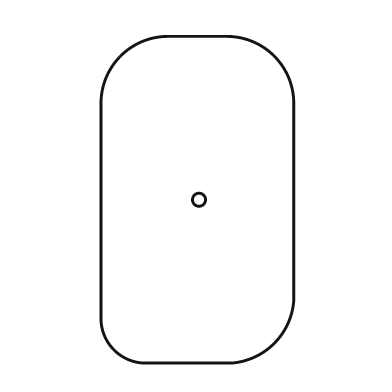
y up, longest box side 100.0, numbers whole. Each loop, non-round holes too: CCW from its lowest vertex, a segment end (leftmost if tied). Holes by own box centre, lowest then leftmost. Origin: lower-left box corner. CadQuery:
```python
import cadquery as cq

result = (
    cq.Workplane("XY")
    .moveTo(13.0, 0.0)
    .lineTo(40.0, 0.0)
    .threePointArc((53.0, 6.0), (59.0, 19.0))
    .lineTo(59.0, 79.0)
    .threePointArc((53.0, 94.0), (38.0, 100.0))
    .lineTo(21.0, 100.0)
    .threePointArc((6.0, 94.0), (0.0, 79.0))
    .lineTo(0.0, 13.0)
    .threePointArc((4.0, 4.0), (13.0, 0.0))
    .close()
    .moveTo(30.0, 50.0)
    .circle(2.0)
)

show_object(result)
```